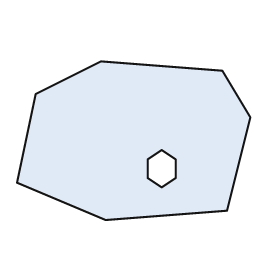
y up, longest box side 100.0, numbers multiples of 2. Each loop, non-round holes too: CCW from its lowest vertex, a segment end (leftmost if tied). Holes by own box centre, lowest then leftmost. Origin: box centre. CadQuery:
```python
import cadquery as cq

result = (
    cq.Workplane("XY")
    .moveTo(-12.0, -34.0)
    .lineTo(40.0, -30.0)
    .lineTo(50.0, 10.0)
    .lineTo(38.0, 30.0)
    .lineTo(-14.0, 34.0)
    .lineTo(-42.0, 20.0)
    .lineTo(-50.0, -18.0)
    .close()
    .moveTo(12.0, -20.0)
    .lineTo(18.0, -16.0)
    .lineTo(18.0, -8.0)
    .lineTo(12.0, -4.0)
    .lineTo(6.0, -8.0)
    .lineTo(6.0, -16.0)
    .close()
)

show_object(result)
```